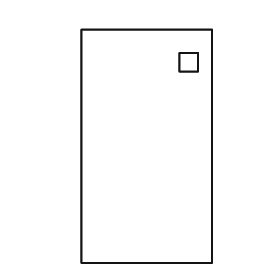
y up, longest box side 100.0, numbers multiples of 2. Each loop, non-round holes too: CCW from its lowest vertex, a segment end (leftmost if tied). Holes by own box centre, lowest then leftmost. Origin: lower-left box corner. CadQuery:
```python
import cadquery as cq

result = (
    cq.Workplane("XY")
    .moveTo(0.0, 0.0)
    .lineTo(56.0, 0.0)
    .lineTo(56.0, 100.0)
    .lineTo(0.0, 100.0)
    .close()
    .moveTo(42.0, 82.0)
    .lineTo(50.0, 82.0)
    .lineTo(50.0, 90.0)
    .lineTo(42.0, 90.0)
    .close()
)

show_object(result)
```